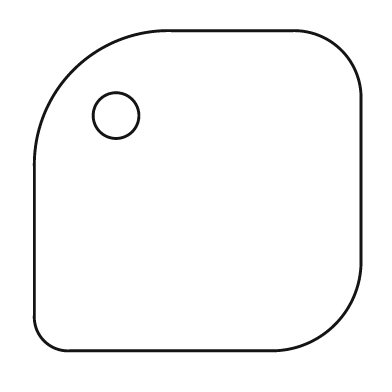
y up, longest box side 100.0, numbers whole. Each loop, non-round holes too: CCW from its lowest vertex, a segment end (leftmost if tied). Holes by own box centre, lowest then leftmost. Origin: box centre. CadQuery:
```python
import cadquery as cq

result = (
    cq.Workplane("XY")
    .moveTo(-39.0, -49.0)
    .lineTo(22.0, -49.0)
    .threePointArc((42.0, -41.0), (50.0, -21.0))
    .lineTo(50.0, 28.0)
    .threePointArc((44.0, 43.0), (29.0, 49.0))
    .lineTo(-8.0, 49.0)
    .threePointArc((-38.0, 37.0), (-50.0, 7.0))
    .lineTo(-50.0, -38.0)
    .threePointArc((-47.0, -46.0), (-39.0, -49.0))
    .close()
    .moveTo(-25.0, 23.0)
    .circle(7.0)
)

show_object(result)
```